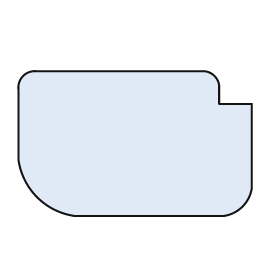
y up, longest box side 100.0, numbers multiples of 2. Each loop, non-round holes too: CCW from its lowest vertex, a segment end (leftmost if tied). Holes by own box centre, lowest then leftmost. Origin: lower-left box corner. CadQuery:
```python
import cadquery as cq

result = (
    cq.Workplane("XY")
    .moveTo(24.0, 0.0)
    .lineTo(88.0, 0.0)
    .threePointArc((96.0, 4.0), (100.0, 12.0))
    .lineTo(100.0, 48.0)
    .lineTo(86.0, 48.0)
    .lineTo(86.0, 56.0)
    .threePointArc((84.0, 60.0), (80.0, 62.0))
    .lineTo(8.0, 62.0)
    .threePointArc((2.0, 60.0), (0.0, 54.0))
    .lineTo(0.0, 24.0)
    .threePointArc((8.0, 8.0), (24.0, 0.0))
    .close()
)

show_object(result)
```